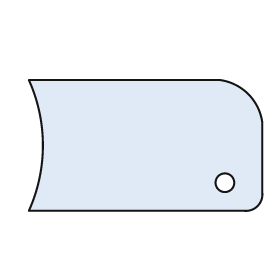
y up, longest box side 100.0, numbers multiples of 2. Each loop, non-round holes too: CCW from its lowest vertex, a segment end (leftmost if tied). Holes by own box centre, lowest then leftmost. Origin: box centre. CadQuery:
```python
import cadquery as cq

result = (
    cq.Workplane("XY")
    .moveTo(-50.0, -28.0)
    .lineTo(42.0, -28.0)
    .threePointArc((48.0, -26.0), (50.0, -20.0))
    .lineTo(50.0, 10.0)
    .threePointArc((44.0, 22.0), (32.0, 28.0))
    .lineTo(-50.0, 28.0)
    .threePointArc((-44.0, 0.0), (-50.0, -28.0))
    .close()
    .moveTo(34.0, -16.0)
    .circle(4.0)
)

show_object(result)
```